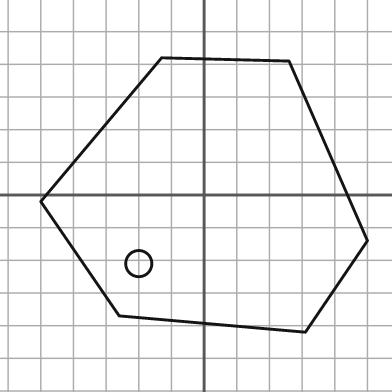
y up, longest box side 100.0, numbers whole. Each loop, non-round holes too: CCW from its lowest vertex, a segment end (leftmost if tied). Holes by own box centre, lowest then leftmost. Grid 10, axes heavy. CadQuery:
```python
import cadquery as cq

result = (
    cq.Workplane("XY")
    .moveTo(31.0, -42.0)
    .lineTo(50.0, -14.0)
    .lineTo(26.0, 41.0)
    .lineTo(-13.0, 42.0)
    .lineTo(-50.0, -2.0)
    .lineTo(-26.0, -37.0)
    .close()
    .moveTo(-20.0, -21.0)
    .circle(4.0)
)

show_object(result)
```